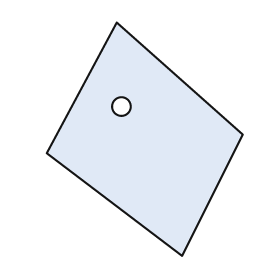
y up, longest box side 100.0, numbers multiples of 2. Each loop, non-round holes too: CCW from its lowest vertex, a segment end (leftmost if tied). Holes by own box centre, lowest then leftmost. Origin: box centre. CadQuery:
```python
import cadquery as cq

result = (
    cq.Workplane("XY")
    .moveTo(16.0, -50.0)
    .lineTo(42.0, 2.0)
    .lineTo(-12.0, 50.0)
    .lineTo(-42.0, -6.0)
    .close()
    .moveTo(-10.0, 14.0)
    .circle(4.0)
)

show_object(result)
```